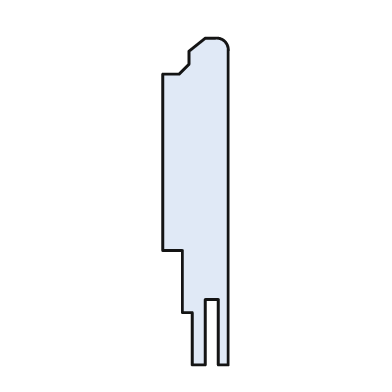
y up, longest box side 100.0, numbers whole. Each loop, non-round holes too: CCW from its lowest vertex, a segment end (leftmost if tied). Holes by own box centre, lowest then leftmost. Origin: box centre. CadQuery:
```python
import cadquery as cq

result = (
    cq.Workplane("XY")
    .moveTo(-1.0, -50.0)
    .lineTo(3.0, -50.0)
    .lineTo(3.0, -30.0)
    .lineTo(7.0, -30.0)
    .lineTo(7.0, -50.0)
    .lineTo(10.0, -50.0)
    .lineTo(10.0, 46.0)
    .threePointArc((9.0, 49.0), (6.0, 50.0))
    .lineTo(3.0, 50.0)
    .lineTo(-2.0, 46.0)
    .lineTo(-2.0, 42.0)
    .lineTo(-5.0, 39.0)
    .lineTo(-10.0, 39.0)
    .lineTo(-10.0, -15.0)
    .lineTo(-4.0, -15.0)
    .lineTo(-4.0, -34.0)
    .lineTo(-1.0, -34.0)
    .close()
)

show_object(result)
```